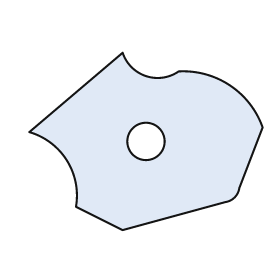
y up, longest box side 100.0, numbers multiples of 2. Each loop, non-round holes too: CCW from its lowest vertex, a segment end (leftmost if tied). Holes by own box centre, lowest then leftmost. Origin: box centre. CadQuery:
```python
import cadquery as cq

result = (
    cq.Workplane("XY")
    .moveTo(-10.0, -38.0)
    .lineTo(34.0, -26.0)
    .threePointArc((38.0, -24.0), (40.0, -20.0))
    .lineTo(50.0, 6.0)
    .threePointArc((36.0, 24.0), (14.0, 30.0))
    .threePointArc((0.0, 28.0), (-10.0, 38.0))
    .lineTo(-50.0, 4.0)
    .threePointArc((-34.0, -8.0), (-30.0, -28.0))
    .close()
    .moveTo(0.0, 0.0)
    .circle(8.0)
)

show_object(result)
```